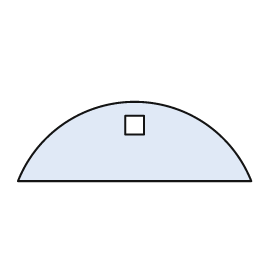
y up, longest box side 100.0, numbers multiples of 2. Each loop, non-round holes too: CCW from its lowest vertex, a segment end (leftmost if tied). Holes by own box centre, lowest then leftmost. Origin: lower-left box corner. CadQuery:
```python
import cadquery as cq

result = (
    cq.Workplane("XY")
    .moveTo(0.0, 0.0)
    .lineTo(100.0, 0.0)
    .threePointArc((50.0, 34.0), (0.0, 0.0))
    .close()
    .moveTo(46.0, 20.0)
    .lineTo(54.0, 20.0)
    .lineTo(54.0, 28.0)
    .lineTo(46.0, 28.0)
    .close()
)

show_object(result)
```